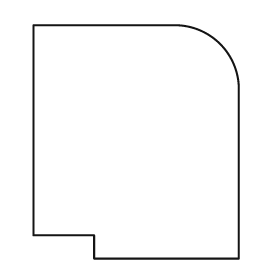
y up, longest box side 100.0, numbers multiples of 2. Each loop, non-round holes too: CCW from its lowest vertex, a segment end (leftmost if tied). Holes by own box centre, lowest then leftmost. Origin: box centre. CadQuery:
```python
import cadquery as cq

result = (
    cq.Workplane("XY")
    .moveTo(-18.0, -50.0)
    .lineTo(44.0, -50.0)
    .lineTo(44.0, 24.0)
    .threePointArc((36.0, 42.0), (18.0, 50.0))
    .lineTo(-44.0, 50.0)
    .lineTo(-44.0, -40.0)
    .lineTo(-18.0, -40.0)
    .close()
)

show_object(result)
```